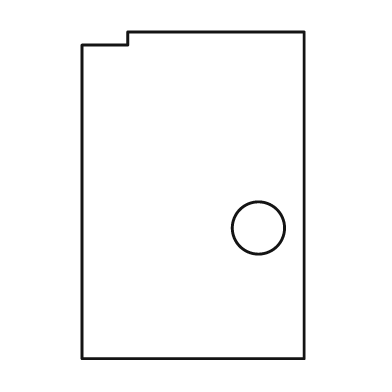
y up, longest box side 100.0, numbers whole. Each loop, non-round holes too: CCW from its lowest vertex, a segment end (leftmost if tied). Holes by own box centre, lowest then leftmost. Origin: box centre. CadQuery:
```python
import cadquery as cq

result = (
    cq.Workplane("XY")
    .moveTo(-34.0, -50.0)
    .lineTo(34.0, -50.0)
    .lineTo(34.0, 50.0)
    .lineTo(-20.0, 50.0)
    .lineTo(-20.0, 46.0)
    .lineTo(-34.0, 46.0)
    .close()
    .moveTo(20.0, -10.0)
    .circle(8.0)
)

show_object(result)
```